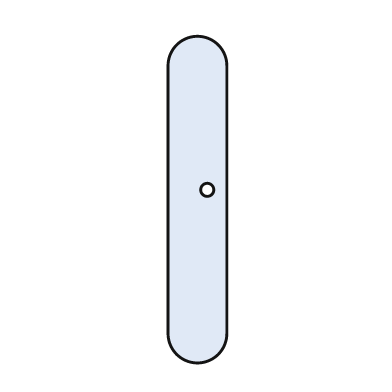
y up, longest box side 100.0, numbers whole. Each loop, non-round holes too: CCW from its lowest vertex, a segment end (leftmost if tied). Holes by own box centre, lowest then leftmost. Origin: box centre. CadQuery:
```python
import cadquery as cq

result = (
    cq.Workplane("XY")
    .moveTo(-9.0, -41.0)
    .threePointArc((0.0, -50.0), (9.0, -41.0))
    .lineTo(9.0, 41.0)
    .threePointArc((0.0, 50.0), (-9.0, 41.0))
    .close()
    .moveTo(3.0, 3.0)
    .circle(2.0)
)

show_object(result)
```